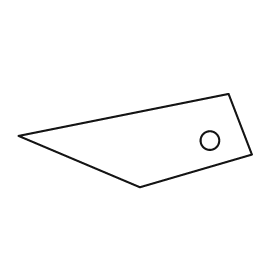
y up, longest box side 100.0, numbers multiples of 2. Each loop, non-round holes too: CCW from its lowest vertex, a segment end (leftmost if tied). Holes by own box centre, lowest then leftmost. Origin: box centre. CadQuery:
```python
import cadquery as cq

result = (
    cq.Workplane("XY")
    .moveTo(2.0, -20.0)
    .lineTo(50.0, -6.0)
    .lineTo(40.0, 20.0)
    .lineTo(-50.0, 2.0)
    .close()
    .moveTo(32.0, 0.0)
    .circle(4.0)
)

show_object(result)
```